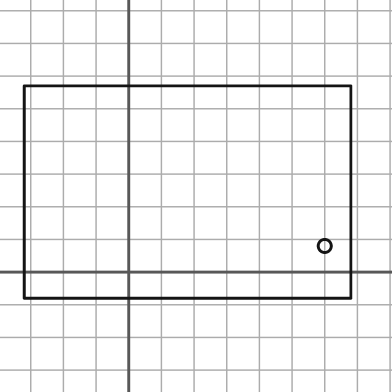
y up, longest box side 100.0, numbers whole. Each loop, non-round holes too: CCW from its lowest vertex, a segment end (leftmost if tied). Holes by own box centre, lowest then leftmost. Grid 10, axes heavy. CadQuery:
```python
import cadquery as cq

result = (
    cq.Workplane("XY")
    .moveTo(-32.0, -8.0)
    .lineTo(68.0, -8.0)
    .lineTo(68.0, 57.0)
    .lineTo(-32.0, 57.0)
    .close()
    .moveTo(60.0, 8.0)
    .circle(2.0)
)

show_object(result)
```